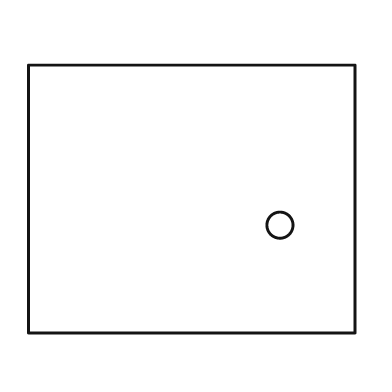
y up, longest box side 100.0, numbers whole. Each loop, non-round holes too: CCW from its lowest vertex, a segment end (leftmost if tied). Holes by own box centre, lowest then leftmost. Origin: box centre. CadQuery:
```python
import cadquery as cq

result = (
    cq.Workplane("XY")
    .moveTo(-50.0, -41.0)
    .lineTo(50.0, -41.0)
    .lineTo(50.0, 41.0)
    .lineTo(-50.0, 41.0)
    .close()
    .moveTo(27.0, -8.0)
    .circle(4.0)
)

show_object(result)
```